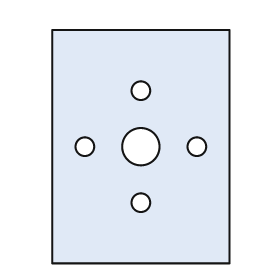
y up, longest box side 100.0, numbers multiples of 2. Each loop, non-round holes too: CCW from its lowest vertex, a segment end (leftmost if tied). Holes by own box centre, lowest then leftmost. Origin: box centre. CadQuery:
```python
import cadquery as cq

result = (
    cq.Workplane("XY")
    .moveTo(-38.0, -50.0)
    .lineTo(38.0, -50.0)
    .lineTo(38.0, 50.0)
    .lineTo(-38.0, 50.0)
    .close()
    .moveTo(0.0, -24.0)
    .circle(4.0)
    .moveTo(-24.0, 0.0)
    .circle(4.0)
    .moveTo(0.0, 0.0)
    .circle(8.0)
    .moveTo(24.0, 0.0)
    .circle(4.0)
    .moveTo(0.0, 24.0)
    .circle(4.0)
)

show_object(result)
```